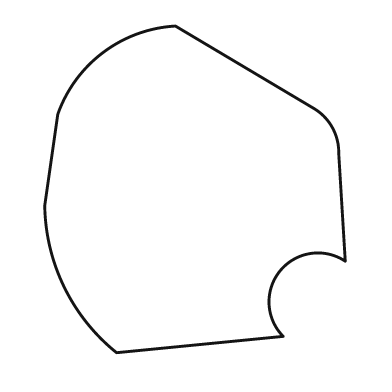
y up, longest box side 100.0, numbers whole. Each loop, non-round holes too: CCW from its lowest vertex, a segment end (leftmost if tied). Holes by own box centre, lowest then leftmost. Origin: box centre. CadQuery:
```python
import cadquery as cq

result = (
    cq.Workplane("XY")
    .moveTo(-24.0, -50.0)
    .lineTo(27.0, -45.0)
    .threePointArc((26.0, -25.0), (46.0, -22.0))
    .lineTo(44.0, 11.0)
    .threePointArc((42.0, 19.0), (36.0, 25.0))
    .lineTo(-6.0, 50.0)
    .threePointArc((-28.0, 42.0), (-42.0, 23.0))
    .lineTo(-46.0, -5.0)
    .threePointArc((-40.0, -30.0), (-24.0, -50.0))
    .close()
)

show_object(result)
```